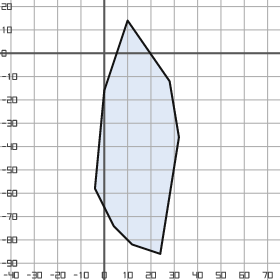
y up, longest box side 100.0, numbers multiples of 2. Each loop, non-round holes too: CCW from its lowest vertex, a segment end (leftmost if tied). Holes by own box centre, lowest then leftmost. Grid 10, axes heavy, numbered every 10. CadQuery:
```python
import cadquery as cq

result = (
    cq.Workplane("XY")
    .moveTo(24.0, -86.0)
    .lineTo(32.0, -36.0)
    .lineTo(28.0, -12.0)
    .lineTo(10.0, 14.0)
    .lineTo(0.0, -16.0)
    .lineTo(-4.0, -58.0)
    .lineTo(4.0, -74.0)
    .lineTo(12.0, -82.0)
    .close()
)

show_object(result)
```